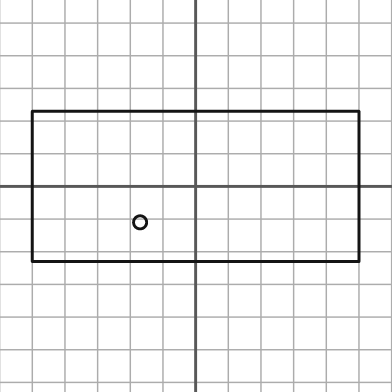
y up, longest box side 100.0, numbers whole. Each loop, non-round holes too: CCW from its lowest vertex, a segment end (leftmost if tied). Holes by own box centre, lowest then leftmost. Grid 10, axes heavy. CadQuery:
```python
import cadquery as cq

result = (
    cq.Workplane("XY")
    .moveTo(-50.0, -23.0)
    .lineTo(50.0, -23.0)
    .lineTo(50.0, 23.0)
    .lineTo(-50.0, 23.0)
    .close()
    .moveTo(-17.0, -11.0)
    .circle(2.0)
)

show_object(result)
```